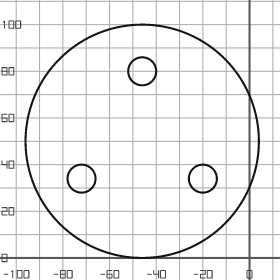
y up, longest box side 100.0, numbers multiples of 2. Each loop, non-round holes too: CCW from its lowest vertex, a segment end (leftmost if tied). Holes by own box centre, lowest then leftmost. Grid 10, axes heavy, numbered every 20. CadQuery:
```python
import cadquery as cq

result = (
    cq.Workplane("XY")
    .moveTo(-46.0, 50.0)
    .circle(50.0)
    .moveTo(-72.0, 34.0)
    .circle(6.0)
    .moveTo(-20.0, 34.0)
    .circle(6.0)
    .moveTo(-46.0, 80.0)
    .circle(6.0)
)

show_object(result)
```